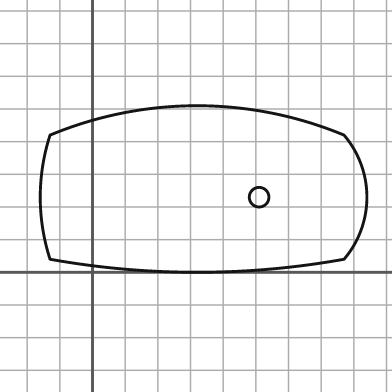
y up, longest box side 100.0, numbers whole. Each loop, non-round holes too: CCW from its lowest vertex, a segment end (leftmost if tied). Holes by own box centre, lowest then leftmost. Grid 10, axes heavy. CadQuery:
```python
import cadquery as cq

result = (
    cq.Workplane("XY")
    .moveTo(-13.0, 4.0)
    .threePointArc((32.0, 0.0), (77.0, 4.0))
    .threePointArc((84.0, 23.0), (77.0, 42.0))
    .threePointArc((32.0, 51.0), (-13.0, 42.0))
    .threePointArc((-16.0, 23.0), (-13.0, 4.0))
    .close()
    .moveTo(51.0, 23.0)
    .circle(3.0)
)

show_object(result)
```